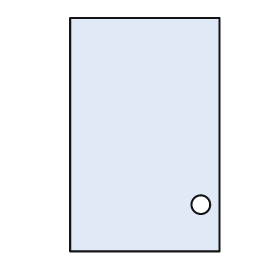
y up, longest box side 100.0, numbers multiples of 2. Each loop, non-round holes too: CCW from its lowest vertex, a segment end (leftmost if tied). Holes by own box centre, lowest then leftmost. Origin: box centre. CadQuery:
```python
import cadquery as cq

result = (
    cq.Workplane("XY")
    .moveTo(-32.0, -50.0)
    .lineTo(32.0, -50.0)
    .lineTo(32.0, 50.0)
    .lineTo(-32.0, 50.0)
    .close()
    .moveTo(24.0, -30.0)
    .circle(4.0)
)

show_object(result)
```